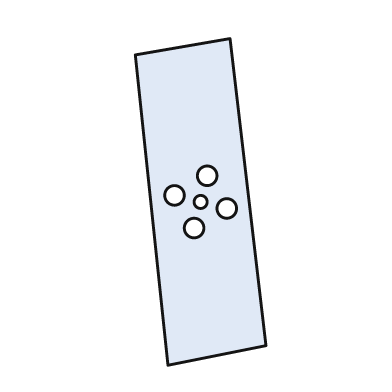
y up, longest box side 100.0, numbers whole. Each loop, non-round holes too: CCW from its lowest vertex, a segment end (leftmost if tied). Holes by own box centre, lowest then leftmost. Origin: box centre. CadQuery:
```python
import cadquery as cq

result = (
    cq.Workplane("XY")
    .moveTo(-10.0, -50.0)
    .lineTo(20.0, -44.0)
    .lineTo(9.0, 50.0)
    .lineTo(-20.0, 45.0)
    .close()
    .moveTo(-2.0, -8.0)
    .circle(3.0)
    .moveTo(8.0, -2.0)
    .circle(3.0)
    .moveTo(0.0, 0.0)
    .circle(2.0)
    .moveTo(-8.0, 2.0)
    .circle(3.0)
    .moveTo(2.0, 8.0)
    .circle(3.0)
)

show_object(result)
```